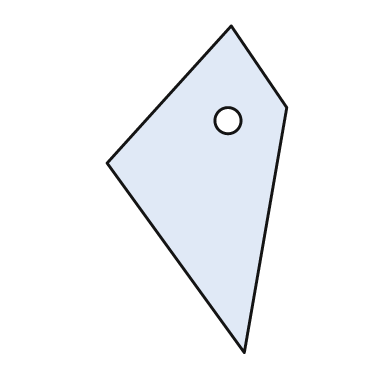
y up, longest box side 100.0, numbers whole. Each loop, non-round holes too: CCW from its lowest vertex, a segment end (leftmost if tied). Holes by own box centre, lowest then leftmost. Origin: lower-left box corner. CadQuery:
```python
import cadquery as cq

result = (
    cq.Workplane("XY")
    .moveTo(42.0, 0.0)
    .lineTo(55.0, 75.0)
    .lineTo(38.0, 100.0)
    .lineTo(0.0, 58.0)
    .close()
    .moveTo(37.0, 71.0)
    .circle(4.0)
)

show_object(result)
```